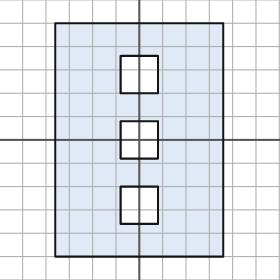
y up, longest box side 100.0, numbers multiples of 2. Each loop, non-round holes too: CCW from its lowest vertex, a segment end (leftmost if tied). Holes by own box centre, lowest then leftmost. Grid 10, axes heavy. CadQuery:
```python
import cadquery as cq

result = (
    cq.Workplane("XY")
    .moveTo(-36.0, -50.0)
    .lineTo(36.0, -50.0)
    .lineTo(36.0, 50.0)
    .lineTo(-36.0, 50.0)
    .close()
    .moveTo(-8.0, -36.0)
    .lineTo(8.0, -36.0)
    .lineTo(8.0, -20.0)
    .lineTo(-8.0, -20.0)
    .close()
    .moveTo(-8.0, -8.0)
    .lineTo(8.0, -8.0)
    .lineTo(8.0, 8.0)
    .lineTo(-8.0, 8.0)
    .close()
    .moveTo(-8.0, 20.0)
    .lineTo(8.0, 20.0)
    .lineTo(8.0, 36.0)
    .lineTo(-8.0, 36.0)
    .close()
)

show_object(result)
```